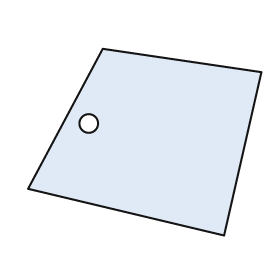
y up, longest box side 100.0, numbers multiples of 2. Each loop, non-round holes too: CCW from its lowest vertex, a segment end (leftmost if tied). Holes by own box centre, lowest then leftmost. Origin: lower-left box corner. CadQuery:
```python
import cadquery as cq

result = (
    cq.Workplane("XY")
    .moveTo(84.0, 0.0)
    .lineTo(100.0, 70.0)
    .lineTo(32.0, 80.0)
    .lineTo(0.0, 20.0)
    .close()
    .moveTo(26.0, 48.0)
    .circle(4.0)
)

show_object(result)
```